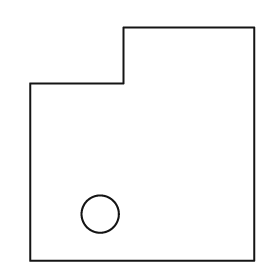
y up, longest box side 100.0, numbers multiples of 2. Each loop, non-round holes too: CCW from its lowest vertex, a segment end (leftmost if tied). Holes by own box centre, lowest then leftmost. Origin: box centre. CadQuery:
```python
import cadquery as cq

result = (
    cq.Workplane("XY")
    .moveTo(-48.0, -50.0)
    .lineTo(48.0, -50.0)
    .lineTo(48.0, 50.0)
    .lineTo(-8.0, 50.0)
    .lineTo(-8.0, 26.0)
    .lineTo(-48.0, 26.0)
    .close()
    .moveTo(-18.0, -30.0)
    .circle(8.0)
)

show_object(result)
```